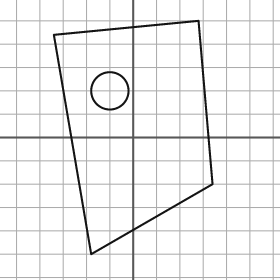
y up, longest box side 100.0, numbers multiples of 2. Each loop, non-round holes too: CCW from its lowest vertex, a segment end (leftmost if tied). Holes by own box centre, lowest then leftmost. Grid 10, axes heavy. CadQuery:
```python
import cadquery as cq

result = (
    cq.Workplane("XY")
    .moveTo(-18.0, -50.0)
    .lineTo(34.0, -20.0)
    .lineTo(28.0, 50.0)
    .lineTo(-34.0, 44.0)
    .close()
    .moveTo(-10.0, 20.0)
    .circle(8.0)
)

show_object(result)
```